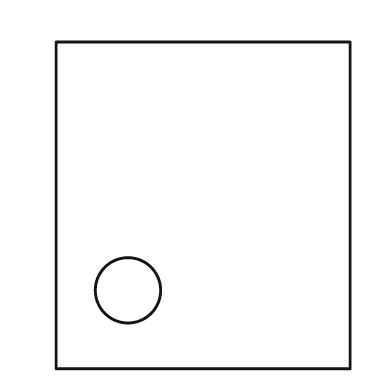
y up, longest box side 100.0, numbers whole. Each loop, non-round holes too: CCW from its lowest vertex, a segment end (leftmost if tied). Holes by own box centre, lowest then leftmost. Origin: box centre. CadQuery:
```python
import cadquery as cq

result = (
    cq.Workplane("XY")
    .moveTo(-45.0, -50.0)
    .lineTo(45.0, -50.0)
    .lineTo(45.0, 50.0)
    .lineTo(-45.0, 50.0)
    .close()
    .moveTo(-23.0, -26.0)
    .circle(10.0)
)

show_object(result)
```